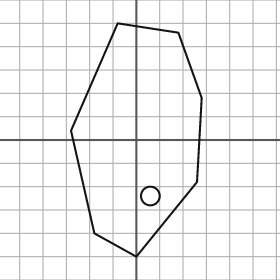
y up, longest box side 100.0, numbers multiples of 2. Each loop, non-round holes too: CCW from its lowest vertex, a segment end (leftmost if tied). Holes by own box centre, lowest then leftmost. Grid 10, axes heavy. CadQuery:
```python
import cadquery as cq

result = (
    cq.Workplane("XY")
    .moveTo(0.0, -50.0)
    .lineTo(26.0, -18.0)
    .lineTo(28.0, 18.0)
    .lineTo(18.0, 46.0)
    .lineTo(-8.0, 50.0)
    .lineTo(-28.0, 4.0)
    .lineTo(-18.0, -40.0)
    .close()
    .moveTo(6.0, -24.0)
    .circle(4.0)
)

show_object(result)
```